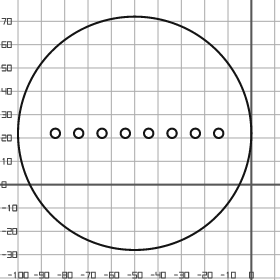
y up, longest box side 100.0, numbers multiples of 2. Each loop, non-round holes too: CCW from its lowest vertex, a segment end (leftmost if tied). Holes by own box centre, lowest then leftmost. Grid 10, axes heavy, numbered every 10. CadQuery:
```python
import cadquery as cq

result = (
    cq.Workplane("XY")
    .moveTo(-50.0, 22.0)
    .circle(50.0)
    .moveTo(-84.0, 22.0)
    .circle(2.0)
    .moveTo(-74.0, 22.0)
    .circle(2.0)
    .moveTo(-64.0, 22.0)
    .circle(2.0)
    .moveTo(-54.0, 22.0)
    .circle(2.0)
    .moveTo(-44.0, 22.0)
    .circle(2.0)
    .moveTo(-34.0, 22.0)
    .circle(2.0)
    .moveTo(-24.0, 22.0)
    .circle(2.0)
    .moveTo(-14.0, 22.0)
    .circle(2.0)
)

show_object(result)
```